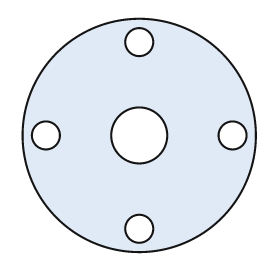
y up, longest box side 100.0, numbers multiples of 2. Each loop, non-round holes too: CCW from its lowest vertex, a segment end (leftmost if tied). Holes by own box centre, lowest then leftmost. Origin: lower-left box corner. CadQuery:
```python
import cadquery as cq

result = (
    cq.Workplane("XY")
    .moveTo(50.0, 50.0)
    .circle(50.0)
    .moveTo(50.0, 10.0)
    .circle(6.0)
    .moveTo(10.0, 50.0)
    .circle(6.0)
    .moveTo(50.0, 50.0)
    .circle(12.0)
    .moveTo(90.0, 50.0)
    .circle(6.0)
    .moveTo(50.0, 90.0)
    .circle(6.0)
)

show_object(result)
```